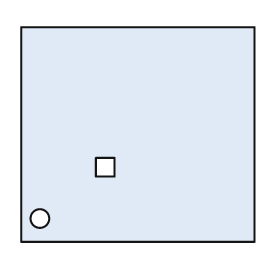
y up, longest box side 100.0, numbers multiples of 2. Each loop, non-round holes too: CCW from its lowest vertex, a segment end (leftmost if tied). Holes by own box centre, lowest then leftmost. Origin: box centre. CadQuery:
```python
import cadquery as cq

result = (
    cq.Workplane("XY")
    .moveTo(-50.0, -46.0)
    .lineTo(50.0, -46.0)
    .lineTo(50.0, 46.0)
    .lineTo(-50.0, 46.0)
    .close()
    .moveTo(-42.0, -36.0)
    .circle(4.0)
    .moveTo(-18.0, -18.0)
    .lineTo(-10.0, -18.0)
    .lineTo(-10.0, -10.0)
    .lineTo(-18.0, -10.0)
    .close()
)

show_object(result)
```